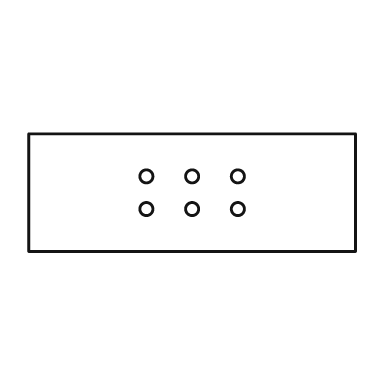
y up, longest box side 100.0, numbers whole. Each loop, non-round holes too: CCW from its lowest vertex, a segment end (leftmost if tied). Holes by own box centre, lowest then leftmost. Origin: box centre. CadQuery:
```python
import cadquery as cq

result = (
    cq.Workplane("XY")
    .moveTo(-50.0, -18.0)
    .lineTo(50.0, -18.0)
    .lineTo(50.0, 18.0)
    .lineTo(-50.0, 18.0)
    .close()
    .moveTo(-14.0, -5.0)
    .circle(2.0)
    .moveTo(0.0, -5.0)
    .circle(2.0)
    .moveTo(14.0, -5.0)
    .circle(2.0)
    .moveTo(-14.0, 5.0)
    .circle(2.0)
    .moveTo(0.0, 5.0)
    .circle(2.0)
    .moveTo(14.0, 5.0)
    .circle(2.0)
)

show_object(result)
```